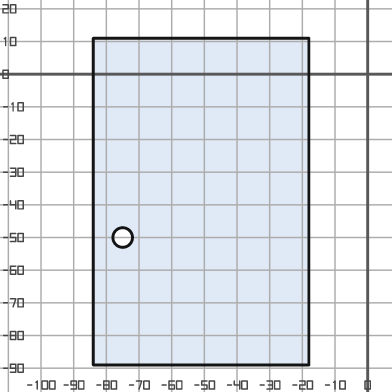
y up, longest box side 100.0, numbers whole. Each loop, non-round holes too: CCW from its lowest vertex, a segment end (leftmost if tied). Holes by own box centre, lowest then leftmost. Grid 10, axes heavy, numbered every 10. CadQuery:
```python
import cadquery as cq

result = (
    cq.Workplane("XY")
    .moveTo(-84.0, -89.0)
    .lineTo(-18.0, -89.0)
    .lineTo(-18.0, 11.0)
    .lineTo(-84.0, 11.0)
    .close()
    .moveTo(-75.0, -50.0)
    .circle(3.0)
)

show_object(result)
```